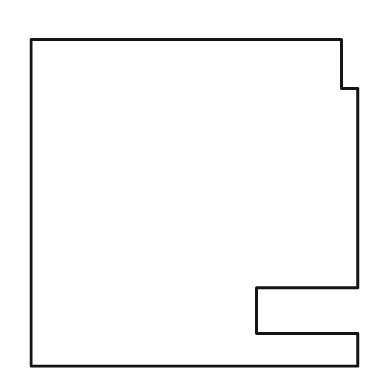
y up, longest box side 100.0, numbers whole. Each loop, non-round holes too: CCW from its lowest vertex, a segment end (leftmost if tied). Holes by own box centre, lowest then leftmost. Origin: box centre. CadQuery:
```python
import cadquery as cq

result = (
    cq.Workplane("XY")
    .moveTo(-50.0, -50.0)
    .lineTo(50.0, -50.0)
    .lineTo(50.0, -40.0)
    .lineTo(19.0, -40.0)
    .lineTo(19.0, -26.0)
    .lineTo(50.0, -26.0)
    .lineTo(50.0, 35.0)
    .lineTo(45.0, 35.0)
    .lineTo(45.0, 50.0)
    .lineTo(-50.0, 50.0)
    .close()
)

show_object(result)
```